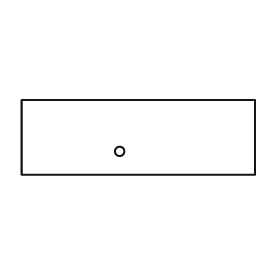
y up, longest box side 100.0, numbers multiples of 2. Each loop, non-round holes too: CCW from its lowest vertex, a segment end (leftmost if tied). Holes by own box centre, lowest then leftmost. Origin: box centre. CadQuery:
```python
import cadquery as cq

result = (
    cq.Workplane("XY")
    .moveTo(-50.0, -16.0)
    .lineTo(50.0, -16.0)
    .lineTo(50.0, 16.0)
    .lineTo(-50.0, 16.0)
    .close()
    .moveTo(-8.0, -6.0)
    .circle(2.0)
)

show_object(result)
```